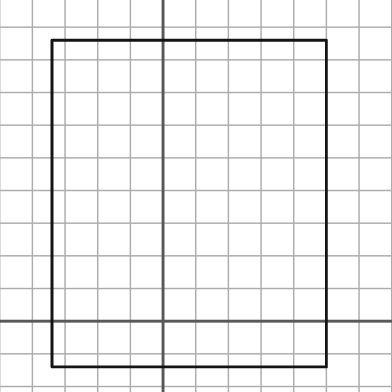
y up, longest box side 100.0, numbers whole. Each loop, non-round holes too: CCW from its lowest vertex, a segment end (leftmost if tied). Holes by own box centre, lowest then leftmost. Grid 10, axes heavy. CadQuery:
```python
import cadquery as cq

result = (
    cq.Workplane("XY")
    .moveTo(-34.0, -14.0)
    .lineTo(50.0, -14.0)
    .lineTo(50.0, 86.0)
    .lineTo(-34.0, 86.0)
    .close()
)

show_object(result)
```